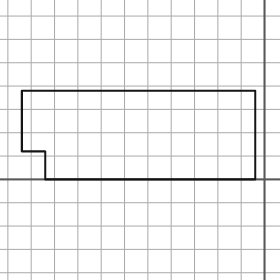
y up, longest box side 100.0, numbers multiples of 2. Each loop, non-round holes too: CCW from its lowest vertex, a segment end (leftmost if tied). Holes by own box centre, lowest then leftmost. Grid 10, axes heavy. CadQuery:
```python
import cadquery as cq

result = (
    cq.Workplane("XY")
    .moveTo(-94.0, 0.0)
    .lineTo(-4.0, 0.0)
    .lineTo(-4.0, 38.0)
    .lineTo(-104.0, 38.0)
    .lineTo(-104.0, 12.0)
    .lineTo(-94.0, 12.0)
    .close()
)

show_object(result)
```